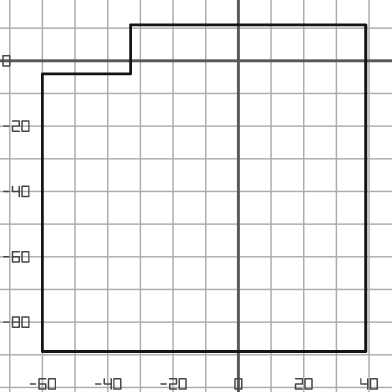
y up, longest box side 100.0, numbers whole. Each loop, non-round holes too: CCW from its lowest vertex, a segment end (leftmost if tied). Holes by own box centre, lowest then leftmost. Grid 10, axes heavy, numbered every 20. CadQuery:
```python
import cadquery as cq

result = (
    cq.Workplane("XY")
    .moveTo(-60.0, -89.0)
    .lineTo(39.0, -89.0)
    .lineTo(39.0, 11.0)
    .lineTo(-33.0, 11.0)
    .lineTo(-33.0, -4.0)
    .lineTo(-60.0, -4.0)
    .close()
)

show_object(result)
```